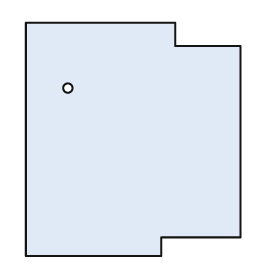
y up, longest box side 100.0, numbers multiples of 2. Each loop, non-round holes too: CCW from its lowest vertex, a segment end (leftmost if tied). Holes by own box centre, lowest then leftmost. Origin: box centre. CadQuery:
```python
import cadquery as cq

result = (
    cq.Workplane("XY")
    .moveTo(-46.0, -50.0)
    .lineTo(12.0, -50.0)
    .lineTo(12.0, -42.0)
    .lineTo(46.0, -42.0)
    .lineTo(46.0, 40.0)
    .lineTo(18.0, 40.0)
    .lineTo(18.0, 50.0)
    .lineTo(-46.0, 50.0)
    .close()
    .moveTo(-28.0, 22.0)
    .circle(2.0)
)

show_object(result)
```